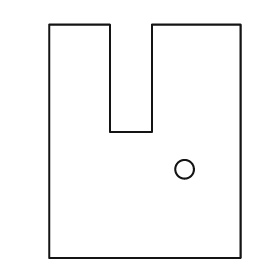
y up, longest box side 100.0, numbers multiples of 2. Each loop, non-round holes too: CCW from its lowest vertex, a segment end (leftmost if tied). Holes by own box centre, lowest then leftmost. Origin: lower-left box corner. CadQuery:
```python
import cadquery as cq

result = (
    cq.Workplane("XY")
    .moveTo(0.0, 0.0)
    .lineTo(82.0, 0.0)
    .lineTo(82.0, 100.0)
    .lineTo(44.0, 100.0)
    .lineTo(44.0, 54.0)
    .lineTo(26.0, 54.0)
    .lineTo(26.0, 100.0)
    .lineTo(0.0, 100.0)
    .close()
    .moveTo(58.0, 38.0)
    .circle(4.0)
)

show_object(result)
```